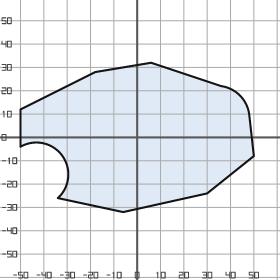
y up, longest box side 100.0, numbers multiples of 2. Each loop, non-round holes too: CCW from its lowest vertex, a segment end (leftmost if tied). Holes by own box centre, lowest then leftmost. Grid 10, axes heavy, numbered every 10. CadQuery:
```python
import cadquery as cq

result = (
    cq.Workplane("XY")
    .moveTo(-6.0, -32.0)
    .lineTo(30.0, -24.0)
    .lineTo(50.0, -8.0)
    .lineTo(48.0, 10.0)
    .threePointArc((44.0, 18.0), (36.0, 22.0))
    .lineTo(6.0, 32.0)
    .lineTo(-18.0, 28.0)
    .lineTo(-50.0, 12.0)
    .lineTo(-50.0, -4.0)
    .threePointArc((-32.0, -8.0), (-34.0, -26.0))
    .close()
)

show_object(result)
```